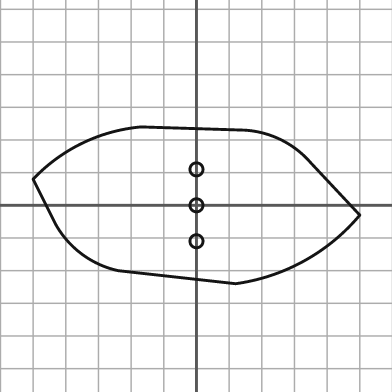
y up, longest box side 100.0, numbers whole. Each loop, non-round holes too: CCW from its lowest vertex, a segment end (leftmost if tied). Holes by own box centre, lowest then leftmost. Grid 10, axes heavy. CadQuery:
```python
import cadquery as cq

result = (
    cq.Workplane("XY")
    .moveTo(12.0, -24.0)
    .threePointArc((33.0, -17.0), (50.0, -3.0))
    .lineTo(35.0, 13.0)
    .threePointArc((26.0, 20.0), (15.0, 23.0))
    .lineTo(-17.0, 24.0)
    .threePointArc((-35.0, 19.0), (-50.0, 8.0))
    .lineTo(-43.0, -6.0)
    .threePointArc((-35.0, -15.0), (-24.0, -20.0))
    .close()
    .moveTo(0.0, -11.0)
    .circle(2.0)
    .moveTo(0.0, 0.0)
    .circle(2.0)
    .moveTo(0.0, 11.0)
    .circle(2.0)
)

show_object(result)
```